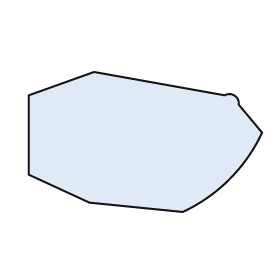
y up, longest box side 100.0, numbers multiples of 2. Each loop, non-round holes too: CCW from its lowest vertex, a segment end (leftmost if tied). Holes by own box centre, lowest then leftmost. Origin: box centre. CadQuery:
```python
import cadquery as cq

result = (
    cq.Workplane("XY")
    .moveTo(16.0, -30.0)
    .threePointArc((36.0, -16.0), (50.0, 4.0))
    .lineTo(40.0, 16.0)
    .threePointArc((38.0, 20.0), (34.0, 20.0))
    .lineTo(-22.0, 30.0)
    .lineTo(-50.0, 20.0)
    .lineTo(-50.0, -14.0)
    .lineTo(-24.0, -26.0)
    .close()
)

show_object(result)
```